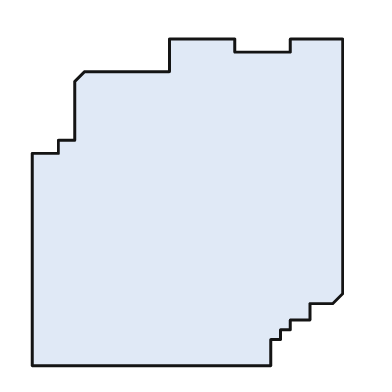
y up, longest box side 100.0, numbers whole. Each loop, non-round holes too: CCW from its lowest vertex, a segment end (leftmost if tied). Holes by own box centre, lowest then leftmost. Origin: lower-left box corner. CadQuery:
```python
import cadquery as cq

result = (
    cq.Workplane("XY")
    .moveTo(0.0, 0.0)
    .lineTo(73.0, 0.0)
    .lineTo(73.0, 8.0)
    .lineTo(76.0, 8.0)
    .lineTo(76.0, 11.0)
    .lineTo(79.0, 11.0)
    .lineTo(79.0, 14.0)
    .lineTo(85.0, 14.0)
    .lineTo(85.0, 19.0)
    .lineTo(92.0, 19.0)
    .lineTo(95.0, 22.0)
    .lineTo(95.0, 100.0)
    .lineTo(79.0, 100.0)
    .lineTo(79.0, 96.0)
    .lineTo(62.0, 96.0)
    .lineTo(62.0, 100.0)
    .lineTo(42.0, 100.0)
    .lineTo(42.0, 90.0)
    .lineTo(16.0, 90.0)
    .lineTo(13.0, 87.0)
    .lineTo(13.0, 69.0)
    .lineTo(8.0, 69.0)
    .lineTo(8.0, 65.0)
    .lineTo(0.0, 65.0)
    .close()
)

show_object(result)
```